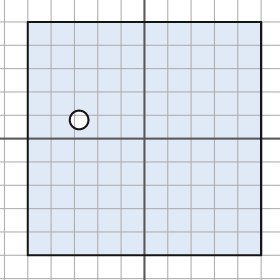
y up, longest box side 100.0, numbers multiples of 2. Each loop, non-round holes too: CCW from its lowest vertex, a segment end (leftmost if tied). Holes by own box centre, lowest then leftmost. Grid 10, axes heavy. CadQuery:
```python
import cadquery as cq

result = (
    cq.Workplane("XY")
    .moveTo(-50.0, -50.0)
    .lineTo(50.0, -50.0)
    .lineTo(50.0, 50.0)
    .lineTo(-50.0, 50.0)
    .close()
    .moveTo(-28.0, 8.0)
    .circle(4.0)
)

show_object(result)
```